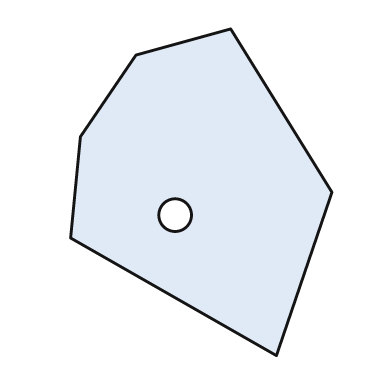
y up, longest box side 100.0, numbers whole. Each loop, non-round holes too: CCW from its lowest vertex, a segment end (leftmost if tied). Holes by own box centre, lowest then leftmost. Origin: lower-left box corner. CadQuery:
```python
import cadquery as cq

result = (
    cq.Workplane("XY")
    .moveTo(63.0, 0.0)
    .lineTo(80.0, 50.0)
    .lineTo(49.0, 100.0)
    .lineTo(20.0, 92.0)
    .lineTo(3.0, 67.0)
    .lineTo(0.0, 36.0)
    .close()
    .moveTo(32.0, 43.0)
    .circle(5.0)
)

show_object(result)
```